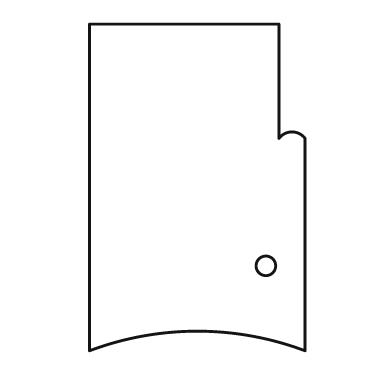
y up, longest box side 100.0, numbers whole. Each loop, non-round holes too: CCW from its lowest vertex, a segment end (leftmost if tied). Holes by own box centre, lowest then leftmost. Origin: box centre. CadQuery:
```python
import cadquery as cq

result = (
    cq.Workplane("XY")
    .moveTo(-33.0, -50.0)
    .threePointArc((0.0, -44.0), (33.0, -50.0))
    .lineTo(33.0, 15.0)
    .threePointArc((29.0, 17.0), (25.0, 15.0))
    .lineTo(25.0, 50.0)
    .lineTo(-33.0, 50.0)
    .close()
    .moveTo(21.0, -24.0)
    .circle(3.0)
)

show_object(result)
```